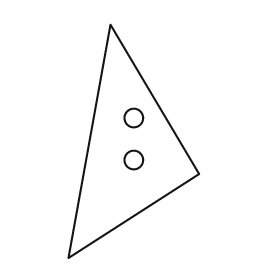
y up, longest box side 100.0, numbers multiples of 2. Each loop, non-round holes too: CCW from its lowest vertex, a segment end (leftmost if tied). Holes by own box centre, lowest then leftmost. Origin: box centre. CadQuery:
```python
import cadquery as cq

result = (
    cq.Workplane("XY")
    .moveTo(-28.0, -50.0)
    .lineTo(28.0, -14.0)
    .lineTo(-10.0, 50.0)
    .close()
    .moveTo(0.0, -8.0)
    .circle(4.0)
    .moveTo(0.0, 10.0)
    .circle(4.0)
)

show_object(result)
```